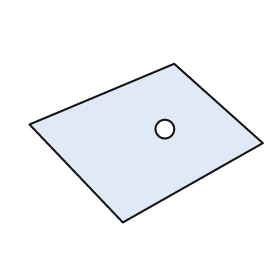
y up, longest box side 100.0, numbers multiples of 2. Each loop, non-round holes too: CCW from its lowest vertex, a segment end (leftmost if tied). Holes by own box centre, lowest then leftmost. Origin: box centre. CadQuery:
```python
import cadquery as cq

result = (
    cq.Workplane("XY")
    .moveTo(-10.0, -34.0)
    .lineTo(50.0, 0.0)
    .lineTo(12.0, 34.0)
    .lineTo(-50.0, 8.0)
    .close()
    .moveTo(8.0, 6.0)
    .circle(4.0)
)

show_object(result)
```